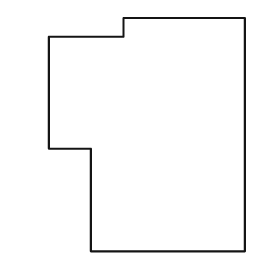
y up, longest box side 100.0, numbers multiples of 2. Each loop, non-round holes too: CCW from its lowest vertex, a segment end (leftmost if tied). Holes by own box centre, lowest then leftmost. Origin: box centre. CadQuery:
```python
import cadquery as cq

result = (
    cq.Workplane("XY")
    .moveTo(-24.0, -50.0)
    .lineTo(42.0, -50.0)
    .lineTo(42.0, 50.0)
    .lineTo(-10.0, 50.0)
    .lineTo(-10.0, 42.0)
    .lineTo(-42.0, 42.0)
    .lineTo(-42.0, -6.0)
    .lineTo(-24.0, -6.0)
    .close()
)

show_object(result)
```